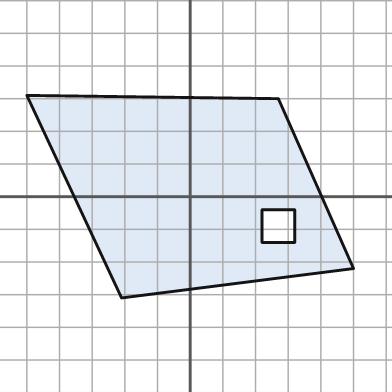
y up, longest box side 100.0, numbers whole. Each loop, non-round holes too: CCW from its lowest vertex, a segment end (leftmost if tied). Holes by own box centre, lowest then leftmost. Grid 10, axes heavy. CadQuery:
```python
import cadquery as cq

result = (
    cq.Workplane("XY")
    .moveTo(-21.0, -31.0)
    .lineTo(50.0, -22.0)
    .lineTo(27.0, 30.0)
    .lineTo(-50.0, 31.0)
    .close()
    .moveTo(22.0, -14.0)
    .lineTo(32.0, -14.0)
    .lineTo(32.0, -4.0)
    .lineTo(22.0, -4.0)
    .close()
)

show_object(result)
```